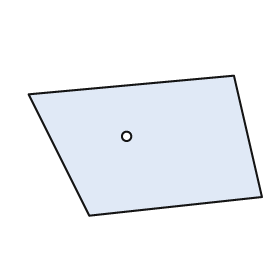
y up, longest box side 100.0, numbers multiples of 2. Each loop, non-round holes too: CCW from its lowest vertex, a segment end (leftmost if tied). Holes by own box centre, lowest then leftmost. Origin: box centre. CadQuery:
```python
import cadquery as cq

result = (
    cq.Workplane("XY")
    .moveTo(-24.0, -30.0)
    .lineTo(50.0, -22.0)
    .lineTo(38.0, 30.0)
    .lineTo(-50.0, 22.0)
    .close()
    .moveTo(-8.0, 4.0)
    .circle(2.0)
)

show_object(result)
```